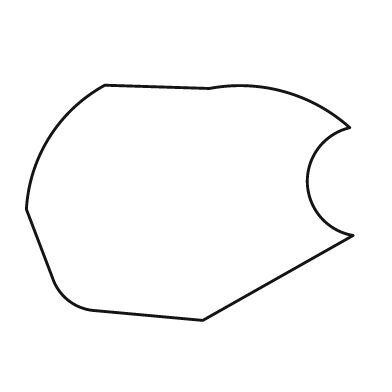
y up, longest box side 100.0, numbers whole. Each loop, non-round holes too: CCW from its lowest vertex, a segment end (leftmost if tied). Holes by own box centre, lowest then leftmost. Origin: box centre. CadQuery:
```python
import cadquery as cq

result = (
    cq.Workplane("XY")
    .moveTo(4.0, -36.0)
    .lineTo(50.0, -10.0)
    .threePointArc((36.0, 6.0), (49.0, 23.0))
    .threePointArc((29.0, 34.0), (6.0, 35.0))
    .lineTo(-26.0, 36.0)
    .threePointArc((-43.0, 20.0), (-50.0, -2.0))
    .lineTo(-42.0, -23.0)
    .threePointArc((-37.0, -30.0), (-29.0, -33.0))
    .close()
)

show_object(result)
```